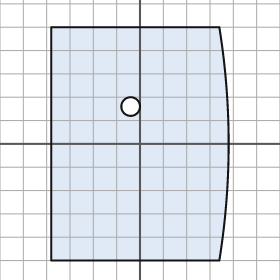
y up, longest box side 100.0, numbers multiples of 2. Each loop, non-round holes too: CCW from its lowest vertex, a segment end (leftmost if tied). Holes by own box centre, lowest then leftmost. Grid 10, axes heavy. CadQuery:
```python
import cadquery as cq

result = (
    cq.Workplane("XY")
    .moveTo(-38.0, -50.0)
    .lineTo(34.0, -50.0)
    .threePointArc((38.0, 0.0), (34.0, 50.0))
    .lineTo(-38.0, 50.0)
    .close()
    .moveTo(-4.0, 16.0)
    .circle(4.0)
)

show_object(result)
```